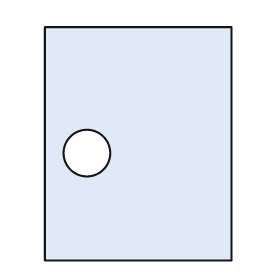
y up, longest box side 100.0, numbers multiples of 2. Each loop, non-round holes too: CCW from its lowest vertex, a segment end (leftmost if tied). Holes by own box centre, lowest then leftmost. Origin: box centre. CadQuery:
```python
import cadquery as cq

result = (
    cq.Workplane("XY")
    .moveTo(-40.0, -50.0)
    .lineTo(40.0, -50.0)
    .lineTo(40.0, 50.0)
    .lineTo(-40.0, 50.0)
    .close()
    .moveTo(-22.0, -4.0)
    .circle(10.0)
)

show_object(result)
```